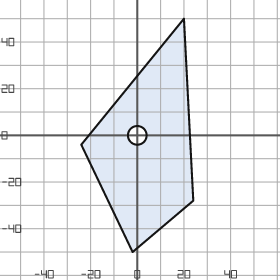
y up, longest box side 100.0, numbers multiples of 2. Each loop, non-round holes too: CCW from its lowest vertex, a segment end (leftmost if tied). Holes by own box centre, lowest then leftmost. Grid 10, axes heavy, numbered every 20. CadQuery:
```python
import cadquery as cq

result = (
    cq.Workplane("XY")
    .moveTo(-2.0, -50.0)
    .lineTo(24.0, -28.0)
    .lineTo(20.0, 50.0)
    .lineTo(-24.0, -4.0)
    .close()
    .moveTo(0.0, 0.0)
    .circle(4.0)
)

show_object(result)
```